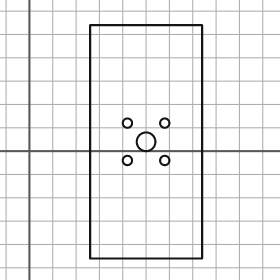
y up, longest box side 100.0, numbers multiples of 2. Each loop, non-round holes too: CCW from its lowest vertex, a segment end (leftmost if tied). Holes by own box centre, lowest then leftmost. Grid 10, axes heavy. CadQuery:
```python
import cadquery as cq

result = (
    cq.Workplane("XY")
    .moveTo(26.0, -46.0)
    .lineTo(74.0, -46.0)
    .lineTo(74.0, 54.0)
    .lineTo(26.0, 54.0)
    .close()
    .moveTo(42.0, -4.0)
    .circle(2.0)
    .moveTo(58.0, -4.0)
    .circle(2.0)
    .moveTo(50.0, 4.0)
    .circle(4.0)
    .moveTo(42.0, 12.0)
    .circle(2.0)
    .moveTo(58.0, 12.0)
    .circle(2.0)
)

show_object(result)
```